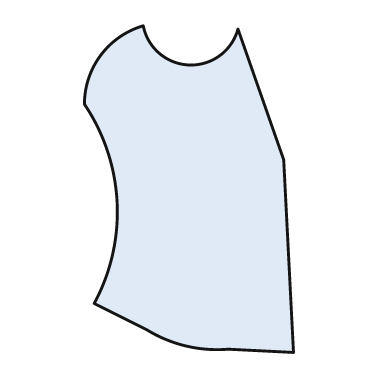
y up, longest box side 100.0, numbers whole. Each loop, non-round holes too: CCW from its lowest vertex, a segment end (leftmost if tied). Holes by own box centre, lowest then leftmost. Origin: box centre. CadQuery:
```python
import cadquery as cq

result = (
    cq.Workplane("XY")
    .moveTo(32.0, -50.0)
    .lineTo(29.0, 9.0)
    .lineTo(15.0, 49.0)
    .threePointArc((0.0, 38.0), (-14.0, 50.0))
    .threePointArc((-27.0, 41.0), (-32.0, 26.0))
    .threePointArc((-22.0, -4.0), (-29.0, -35.0))
    .lineTo(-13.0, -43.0)
    .threePointArc((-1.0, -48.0), (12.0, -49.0))
    .close()
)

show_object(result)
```